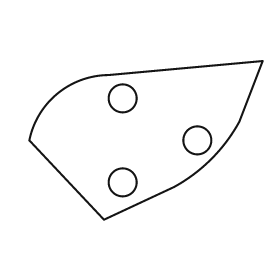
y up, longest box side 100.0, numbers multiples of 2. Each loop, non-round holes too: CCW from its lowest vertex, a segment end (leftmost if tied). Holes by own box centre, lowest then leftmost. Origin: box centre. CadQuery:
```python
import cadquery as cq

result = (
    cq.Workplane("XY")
    .moveTo(-18.0, -34.0)
    .lineTo(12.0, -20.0)
    .threePointArc((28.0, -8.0), (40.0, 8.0))
    .lineTo(50.0, 34.0)
    .lineTo(-16.0, 28.0)
    .threePointArc((-38.0, 20.0), (-50.0, 0.0))
    .close()
    .moveTo(-10.0, -18.0)
    .circle(6.0)
    .moveTo(22.0, 0.0)
    .circle(6.0)
    .moveTo(-10.0, 18.0)
    .circle(6.0)
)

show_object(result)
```